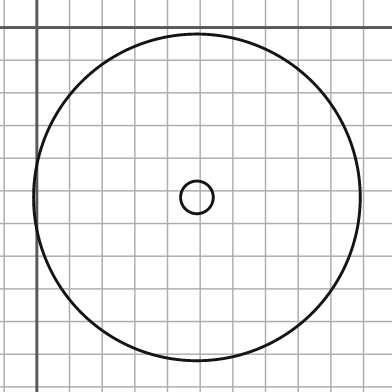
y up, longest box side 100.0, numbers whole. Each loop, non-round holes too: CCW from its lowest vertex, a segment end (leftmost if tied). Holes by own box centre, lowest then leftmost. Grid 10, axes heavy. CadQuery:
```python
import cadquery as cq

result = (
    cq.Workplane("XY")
    .moveTo(49.0, -52.0)
    .circle(50.0)
    .moveTo(49.0, -52.0)
    .circle(5.0)
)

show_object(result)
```